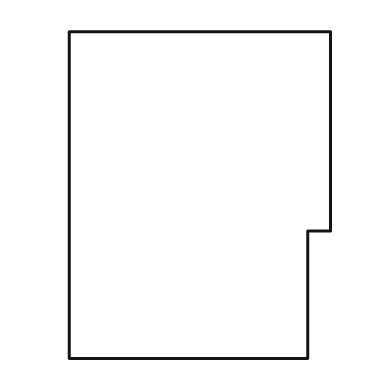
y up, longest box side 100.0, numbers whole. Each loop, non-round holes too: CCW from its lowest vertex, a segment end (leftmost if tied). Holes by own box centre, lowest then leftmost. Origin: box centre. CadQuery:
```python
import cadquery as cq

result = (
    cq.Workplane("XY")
    .moveTo(-40.0, -50.0)
    .lineTo(33.0, -50.0)
    .lineTo(33.0, -11.0)
    .lineTo(40.0, -11.0)
    .lineTo(40.0, 50.0)
    .lineTo(-40.0, 50.0)
    .close()
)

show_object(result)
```